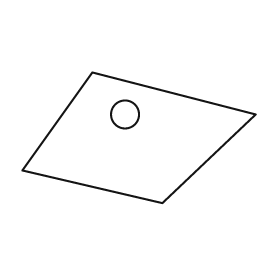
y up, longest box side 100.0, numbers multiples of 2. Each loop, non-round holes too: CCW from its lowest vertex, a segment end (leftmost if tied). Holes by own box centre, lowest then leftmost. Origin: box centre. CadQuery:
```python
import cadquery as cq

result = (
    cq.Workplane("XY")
    .moveTo(10.0, -28.0)
    .lineTo(50.0, 10.0)
    .lineTo(-20.0, 28.0)
    .lineTo(-50.0, -14.0)
    .close()
    .moveTo(-6.0, 10.0)
    .circle(6.0)
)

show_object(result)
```